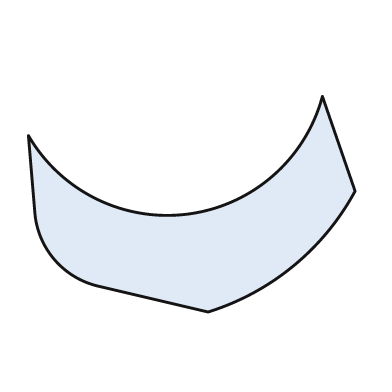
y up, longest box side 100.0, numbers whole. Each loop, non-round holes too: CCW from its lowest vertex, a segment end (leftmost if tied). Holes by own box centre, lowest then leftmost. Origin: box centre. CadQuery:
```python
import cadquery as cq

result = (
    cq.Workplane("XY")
    .moveTo(5.0, -33.0)
    .threePointArc((31.0, -19.0), (50.0, 4.0))
    .lineTo(40.0, 33.0)
    .threePointArc((-1.0, -3.0), (-50.0, 21.0))
    .lineTo(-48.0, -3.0)
    .threePointArc((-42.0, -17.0), (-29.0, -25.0))
    .close()
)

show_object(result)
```